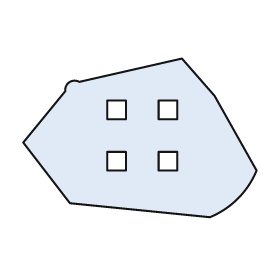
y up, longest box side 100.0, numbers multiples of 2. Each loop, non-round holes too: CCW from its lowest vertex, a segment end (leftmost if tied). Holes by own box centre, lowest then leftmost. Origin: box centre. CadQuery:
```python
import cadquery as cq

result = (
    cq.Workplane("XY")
    .moveTo(30.0, -34.0)
    .threePointArc((42.0, -26.0), (50.0, -14.0))
    .lineTo(32.0, 18.0)
    .lineTo(18.0, 34.0)
    .lineTo(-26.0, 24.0)
    .threePointArc((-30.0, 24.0), (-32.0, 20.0))
    .lineTo(-50.0, -2.0)
    .lineTo(-30.0, -28.0)
    .close()
    .moveTo(-14.0, -14.0)
    .lineTo(-6.0, -14.0)
    .lineTo(-6.0, -6.0)
    .lineTo(-14.0, -6.0)
    .close()
    .moveTo(8.0, -14.0)
    .lineTo(16.0, -14.0)
    .lineTo(16.0, -6.0)
    .lineTo(8.0, -6.0)
    .close()
    .moveTo(-14.0, 8.0)
    .lineTo(-6.0, 8.0)
    .lineTo(-6.0, 16.0)
    .lineTo(-14.0, 16.0)
    .close()
    .moveTo(8.0, 8.0)
    .lineTo(16.0, 8.0)
    .lineTo(16.0, 16.0)
    .lineTo(8.0, 16.0)
    .close()
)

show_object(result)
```